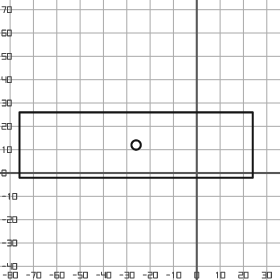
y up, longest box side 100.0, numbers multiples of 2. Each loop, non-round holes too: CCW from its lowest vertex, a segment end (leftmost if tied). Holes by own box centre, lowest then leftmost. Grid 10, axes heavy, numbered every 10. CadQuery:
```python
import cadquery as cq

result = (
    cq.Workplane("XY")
    .moveTo(-76.0, -2.0)
    .lineTo(24.0, -2.0)
    .lineTo(24.0, 26.0)
    .lineTo(-76.0, 26.0)
    .close()
    .moveTo(-26.0, 12.0)
    .circle(2.0)
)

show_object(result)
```